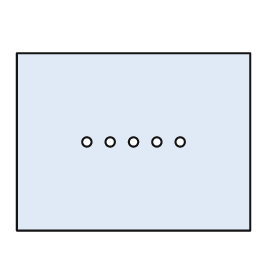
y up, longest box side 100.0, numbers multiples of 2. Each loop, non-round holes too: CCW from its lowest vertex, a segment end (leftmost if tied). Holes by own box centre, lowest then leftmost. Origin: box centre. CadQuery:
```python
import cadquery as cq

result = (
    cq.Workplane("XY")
    .moveTo(-50.0, -38.0)
    .lineTo(50.0, -38.0)
    .lineTo(50.0, 38.0)
    .lineTo(-50.0, 38.0)
    .close()
    .moveTo(-20.0, 0.0)
    .circle(2.0)
    .moveTo(-10.0, 0.0)
    .circle(2.0)
    .moveTo(0.0, 0.0)
    .circle(2.0)
    .moveTo(10.0, 0.0)
    .circle(2.0)
    .moveTo(20.0, 0.0)
    .circle(2.0)
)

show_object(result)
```